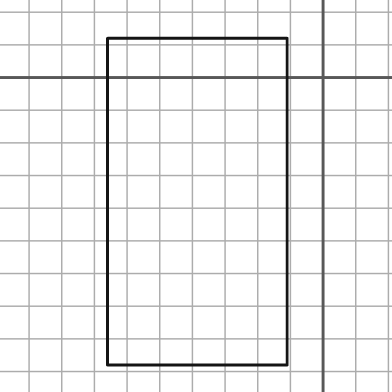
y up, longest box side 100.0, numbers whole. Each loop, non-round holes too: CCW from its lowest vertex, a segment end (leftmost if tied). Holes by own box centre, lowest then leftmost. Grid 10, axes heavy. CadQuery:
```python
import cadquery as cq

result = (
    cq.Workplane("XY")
    .moveTo(-66.0, -88.0)
    .lineTo(-11.0, -88.0)
    .lineTo(-11.0, 12.0)
    .lineTo(-66.0, 12.0)
    .close()
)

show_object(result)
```